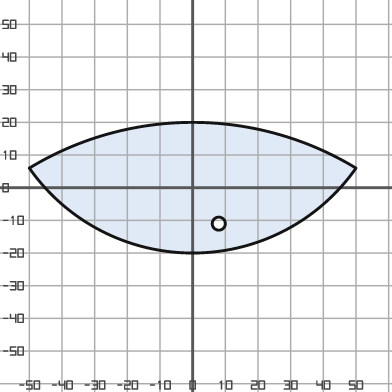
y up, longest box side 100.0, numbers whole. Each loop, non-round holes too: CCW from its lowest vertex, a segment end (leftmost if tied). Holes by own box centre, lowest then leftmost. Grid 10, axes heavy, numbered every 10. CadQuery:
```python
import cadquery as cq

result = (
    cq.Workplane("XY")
    .moveTo(-50.0, 6.0)
    .threePointArc((0.0, -20.0), (50.0, 6.0))
    .threePointArc((0.0, 20.0), (-50.0, 6.0))
    .close()
    .moveTo(8.0, -11.0)
    .circle(2.0)
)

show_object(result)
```